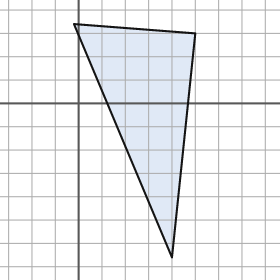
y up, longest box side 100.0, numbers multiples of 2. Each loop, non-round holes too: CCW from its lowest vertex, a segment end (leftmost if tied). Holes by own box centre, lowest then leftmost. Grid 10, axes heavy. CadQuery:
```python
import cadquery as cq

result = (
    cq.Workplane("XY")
    .moveTo(40.0, -66.0)
    .lineTo(50.0, 30.0)
    .lineTo(-2.0, 34.0)
    .close()
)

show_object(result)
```